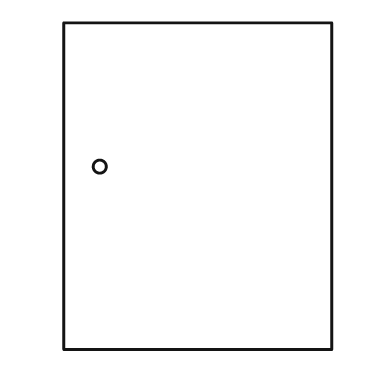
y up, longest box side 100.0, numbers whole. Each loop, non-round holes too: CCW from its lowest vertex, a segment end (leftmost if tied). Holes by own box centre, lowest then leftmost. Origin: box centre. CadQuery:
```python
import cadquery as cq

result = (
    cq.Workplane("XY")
    .moveTo(-41.0, -50.0)
    .lineTo(41.0, -50.0)
    .lineTo(41.0, 50.0)
    .lineTo(-41.0, 50.0)
    .close()
    .moveTo(-30.0, 6.0)
    .circle(2.0)
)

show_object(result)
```